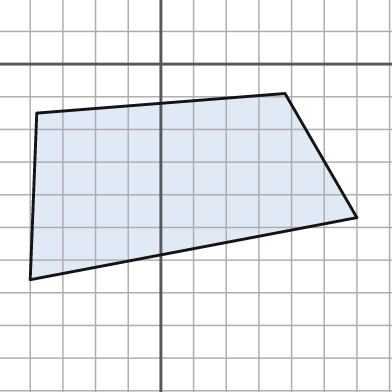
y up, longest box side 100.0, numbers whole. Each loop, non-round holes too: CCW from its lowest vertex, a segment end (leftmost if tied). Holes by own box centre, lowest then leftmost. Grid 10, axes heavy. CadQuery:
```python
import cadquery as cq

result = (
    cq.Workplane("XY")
    .moveTo(-40.0, -66.0)
    .lineTo(60.0, -47.0)
    .lineTo(38.0, -9.0)
    .lineTo(-38.0, -15.0)
    .close()
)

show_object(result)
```